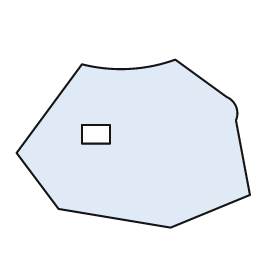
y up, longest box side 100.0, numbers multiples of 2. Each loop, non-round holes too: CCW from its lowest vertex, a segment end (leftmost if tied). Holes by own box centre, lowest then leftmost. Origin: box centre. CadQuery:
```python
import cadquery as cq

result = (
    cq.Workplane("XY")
    .moveTo(16.0, -36.0)
    .lineTo(50.0, -22.0)
    .lineTo(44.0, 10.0)
    .threePointArc((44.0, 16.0), (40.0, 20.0))
    .lineTo(18.0, 36.0)
    .threePointArc((-2.0, 32.0), (-22.0, 34.0))
    .lineTo(-50.0, -4.0)
    .lineTo(-32.0, -28.0)
    .close()
    .moveTo(-22.0, 0.0)
    .lineTo(-10.0, 0.0)
    .lineTo(-10.0, 8.0)
    .lineTo(-22.0, 8.0)
    .close()
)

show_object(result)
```